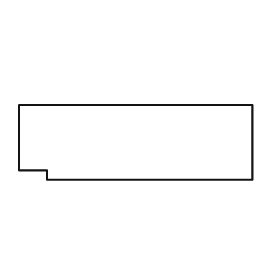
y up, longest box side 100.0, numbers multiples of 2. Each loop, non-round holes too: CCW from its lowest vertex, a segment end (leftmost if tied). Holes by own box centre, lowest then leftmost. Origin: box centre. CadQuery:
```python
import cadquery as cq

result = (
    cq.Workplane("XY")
    .moveTo(-38.0, -16.0)
    .lineTo(50.0, -16.0)
    .lineTo(50.0, 16.0)
    .lineTo(-50.0, 16.0)
    .lineTo(-50.0, -12.0)
    .lineTo(-38.0, -12.0)
    .close()
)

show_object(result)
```